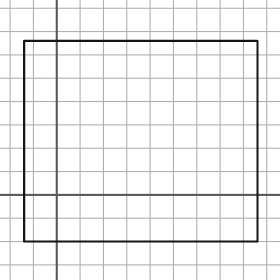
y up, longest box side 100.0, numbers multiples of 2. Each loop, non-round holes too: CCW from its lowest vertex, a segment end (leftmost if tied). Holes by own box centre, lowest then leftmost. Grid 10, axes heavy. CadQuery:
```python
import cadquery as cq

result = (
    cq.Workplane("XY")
    .moveTo(-14.0, -20.0)
    .lineTo(86.0, -20.0)
    .lineTo(86.0, 66.0)
    .lineTo(-14.0, 66.0)
    .close()
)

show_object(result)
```